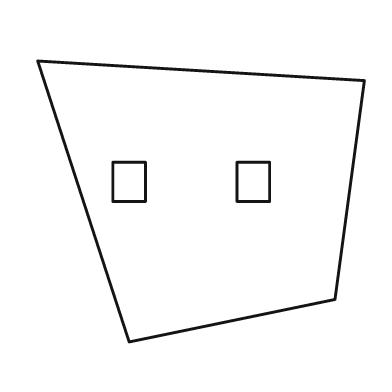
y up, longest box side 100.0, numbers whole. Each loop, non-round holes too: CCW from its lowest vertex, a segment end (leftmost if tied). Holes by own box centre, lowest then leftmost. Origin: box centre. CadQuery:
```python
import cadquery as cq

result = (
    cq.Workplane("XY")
    .moveTo(-22.0, -43.0)
    .lineTo(41.0, -30.0)
    .lineTo(50.0, 37.0)
    .lineTo(-50.0, 43.0)
    .close()
    .moveTo(-27.0, 0.0)
    .lineTo(-17.0, 0.0)
    .lineTo(-17.0, 12.0)
    .lineTo(-27.0, 12.0)
    .close()
    .moveTo(11.0, 0.0)
    .lineTo(21.0, 0.0)
    .lineTo(21.0, 12.0)
    .lineTo(11.0, 12.0)
    .close()
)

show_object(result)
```